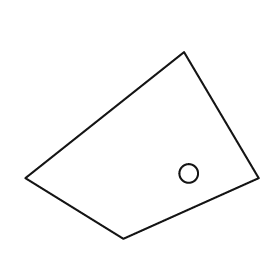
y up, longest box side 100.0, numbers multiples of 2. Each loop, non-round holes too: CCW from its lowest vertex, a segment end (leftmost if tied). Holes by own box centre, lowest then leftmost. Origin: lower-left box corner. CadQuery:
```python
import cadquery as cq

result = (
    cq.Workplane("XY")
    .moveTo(42.0, 0.0)
    .lineTo(100.0, 26.0)
    .lineTo(68.0, 80.0)
    .lineTo(0.0, 26.0)
    .close()
    .moveTo(70.0, 28.0)
    .circle(4.0)
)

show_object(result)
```